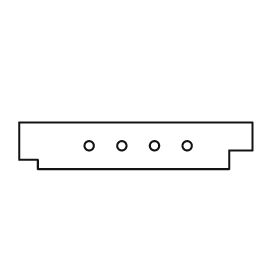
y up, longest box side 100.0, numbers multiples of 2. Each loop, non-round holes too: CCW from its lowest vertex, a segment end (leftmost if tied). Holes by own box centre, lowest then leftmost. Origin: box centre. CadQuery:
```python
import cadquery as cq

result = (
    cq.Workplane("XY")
    .moveTo(-42.0, -10.0)
    .lineTo(40.0, -10.0)
    .lineTo(40.0, -2.0)
    .lineTo(50.0, -2.0)
    .lineTo(50.0, 10.0)
    .lineTo(-50.0, 10.0)
    .lineTo(-50.0, -6.0)
    .lineTo(-42.0, -6.0)
    .close()
    .moveTo(-20.0, 0.0)
    .circle(2.0)
    .moveTo(-6.0, 0.0)
    .circle(2.0)
    .moveTo(8.0, 0.0)
    .circle(2.0)
    .moveTo(22.0, 0.0)
    .circle(2.0)
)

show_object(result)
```